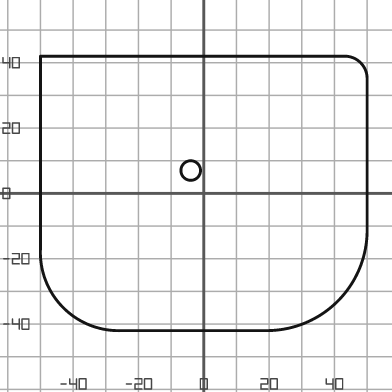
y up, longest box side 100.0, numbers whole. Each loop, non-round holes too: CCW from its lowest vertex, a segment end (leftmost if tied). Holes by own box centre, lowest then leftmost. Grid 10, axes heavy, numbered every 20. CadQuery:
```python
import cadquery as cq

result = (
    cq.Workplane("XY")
    .moveTo(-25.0, -42.0)
    .lineTo(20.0, -42.0)
    .threePointArc((41.0, -33.0), (50.0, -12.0))
    .lineTo(50.0, 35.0)
    .threePointArc((48.0, 40.0), (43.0, 42.0))
    .lineTo(-50.0, 42.0)
    .lineTo(-50.0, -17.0)
    .threePointArc((-43.0, -35.0), (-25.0, -42.0))
    .close()
    .moveTo(-4.0, 7.0)
    .circle(3.0)
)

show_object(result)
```